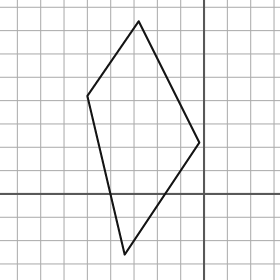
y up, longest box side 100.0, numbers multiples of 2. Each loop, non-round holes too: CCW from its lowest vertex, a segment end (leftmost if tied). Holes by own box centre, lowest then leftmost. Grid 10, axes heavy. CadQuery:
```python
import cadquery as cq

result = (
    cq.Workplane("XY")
    .moveTo(-34.0, -26.0)
    .lineTo(-2.0, 22.0)
    .lineTo(-28.0, 74.0)
    .lineTo(-50.0, 42.0)
    .close()
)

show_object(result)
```